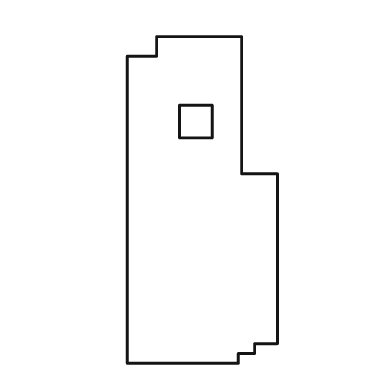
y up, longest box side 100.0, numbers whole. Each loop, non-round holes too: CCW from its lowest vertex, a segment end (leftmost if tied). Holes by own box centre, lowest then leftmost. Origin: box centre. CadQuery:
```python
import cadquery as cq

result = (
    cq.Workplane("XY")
    .moveTo(-23.0, -50.0)
    .lineTo(11.0, -50.0)
    .lineTo(11.0, -47.0)
    .lineTo(16.0, -47.0)
    .lineTo(16.0, -44.0)
    .lineTo(23.0, -44.0)
    .lineTo(23.0, 8.0)
    .lineTo(12.0, 8.0)
    .lineTo(12.0, 50.0)
    .lineTo(-14.0, 50.0)
    .lineTo(-14.0, 44.0)
    .lineTo(-23.0, 44.0)
    .close()
    .moveTo(-7.0, 19.0)
    .lineTo(3.0, 19.0)
    .lineTo(3.0, 29.0)
    .lineTo(-7.0, 29.0)
    .close()
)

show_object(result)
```